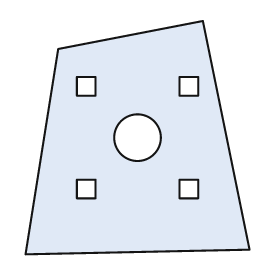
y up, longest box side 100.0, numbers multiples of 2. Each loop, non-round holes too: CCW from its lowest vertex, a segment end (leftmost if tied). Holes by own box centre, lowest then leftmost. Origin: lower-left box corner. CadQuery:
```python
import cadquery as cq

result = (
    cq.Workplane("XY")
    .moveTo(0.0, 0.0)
    .lineTo(96.0, 2.0)
    .lineTo(76.0, 100.0)
    .lineTo(14.0, 88.0)
    .close()
    .moveTo(22.0, 24.0)
    .lineTo(30.0, 24.0)
    .lineTo(30.0, 32.0)
    .lineTo(22.0, 32.0)
    .close()
    .moveTo(66.0, 24.0)
    .lineTo(74.0, 24.0)
    .lineTo(74.0, 32.0)
    .lineTo(66.0, 32.0)
    .close()
    .moveTo(48.0, 50.0)
    .circle(10.0)
    .moveTo(22.0, 68.0)
    .lineTo(30.0, 68.0)
    .lineTo(30.0, 76.0)
    .lineTo(22.0, 76.0)
    .close()
    .moveTo(66.0, 68.0)
    .lineTo(74.0, 68.0)
    .lineTo(74.0, 76.0)
    .lineTo(66.0, 76.0)
    .close()
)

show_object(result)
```